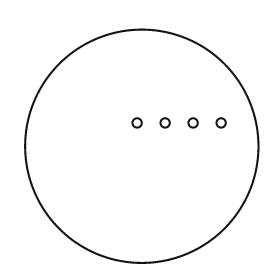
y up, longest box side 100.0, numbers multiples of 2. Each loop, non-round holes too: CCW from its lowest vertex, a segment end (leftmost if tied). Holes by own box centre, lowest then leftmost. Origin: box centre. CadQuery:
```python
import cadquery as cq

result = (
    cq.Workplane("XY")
    .moveTo(0.0, 0.0)
    .circle(50.0)
    .moveTo(-2.0, 10.0)
    .circle(2.0)
    .moveTo(10.0, 10.0)
    .circle(2.0)
    .moveTo(22.0, 10.0)
    .circle(2.0)
    .moveTo(34.0, 10.0)
    .circle(2.0)
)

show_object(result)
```